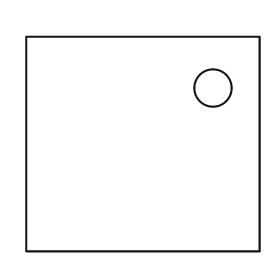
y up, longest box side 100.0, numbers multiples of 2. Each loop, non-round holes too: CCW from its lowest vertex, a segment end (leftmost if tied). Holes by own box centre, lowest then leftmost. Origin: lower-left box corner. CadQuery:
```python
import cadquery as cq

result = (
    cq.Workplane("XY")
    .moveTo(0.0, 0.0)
    .lineTo(100.0, 0.0)
    .lineTo(100.0, 92.0)
    .lineTo(0.0, 92.0)
    .close()
    .moveTo(80.0, 70.0)
    .circle(8.0)
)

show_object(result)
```